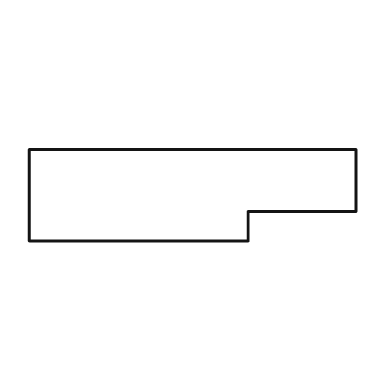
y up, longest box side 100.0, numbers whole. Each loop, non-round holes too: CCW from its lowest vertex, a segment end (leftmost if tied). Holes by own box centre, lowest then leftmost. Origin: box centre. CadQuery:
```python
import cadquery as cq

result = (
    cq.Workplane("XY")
    .moveTo(-50.0, -14.0)
    .lineTo(17.0, -14.0)
    .lineTo(17.0, -5.0)
    .lineTo(50.0, -5.0)
    .lineTo(50.0, 14.0)
    .lineTo(-50.0, 14.0)
    .close()
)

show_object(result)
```